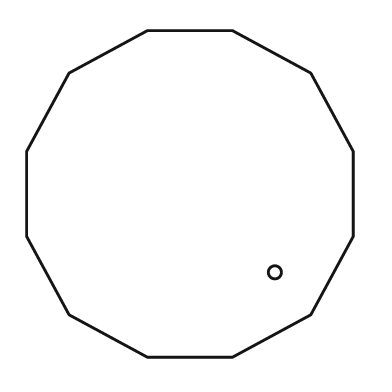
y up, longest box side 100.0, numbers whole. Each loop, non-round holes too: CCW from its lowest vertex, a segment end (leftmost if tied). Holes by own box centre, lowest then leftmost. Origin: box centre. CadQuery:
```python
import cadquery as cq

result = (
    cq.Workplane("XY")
    .moveTo(-13.0, -50.0)
    .lineTo(13.0, -50.0)
    .lineTo(37.0, -37.0)
    .lineTo(50.0, -13.0)
    .lineTo(50.0, 13.0)
    .lineTo(37.0, 37.0)
    .lineTo(13.0, 50.0)
    .lineTo(-13.0, 50.0)
    .lineTo(-37.0, 37.0)
    .lineTo(-50.0, 13.0)
    .lineTo(-50.0, -13.0)
    .lineTo(-37.0, -37.0)
    .close()
    .moveTo(26.0, -24.0)
    .circle(2.0)
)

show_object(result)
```